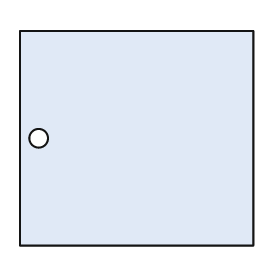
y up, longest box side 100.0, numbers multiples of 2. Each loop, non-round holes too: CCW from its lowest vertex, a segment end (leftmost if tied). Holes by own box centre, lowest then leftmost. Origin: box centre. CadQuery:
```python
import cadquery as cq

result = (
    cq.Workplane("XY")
    .moveTo(-50.0, -46.0)
    .lineTo(50.0, -46.0)
    .lineTo(50.0, 46.0)
    .lineTo(-50.0, 46.0)
    .close()
    .moveTo(-42.0, 0.0)
    .circle(4.0)
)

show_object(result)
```